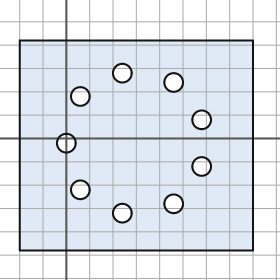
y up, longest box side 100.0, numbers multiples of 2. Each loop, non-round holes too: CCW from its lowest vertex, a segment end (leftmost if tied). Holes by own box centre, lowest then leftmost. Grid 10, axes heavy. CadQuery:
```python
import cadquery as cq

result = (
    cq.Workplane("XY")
    .moveTo(-20.0, -48.0)
    .lineTo(80.0, -48.0)
    .lineTo(80.0, 42.0)
    .lineTo(-20.0, 42.0)
    .close()
    .moveTo(24.0, -32.0)
    .circle(4.0)
    .moveTo(46.0, -28.0)
    .circle(4.0)
    .moveTo(6.0, -22.0)
    .circle(4.0)
    .moveTo(58.0, -12.0)
    .circle(4.0)
    .moveTo(0.0, -2.0)
    .circle(4.0)
    .moveTo(58.0, 8.0)
    .circle(4.0)
    .moveTo(6.0, 18.0)
    .circle(4.0)
    .moveTo(46.0, 24.0)
    .circle(4.0)
    .moveTo(24.0, 28.0)
    .circle(4.0)
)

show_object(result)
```